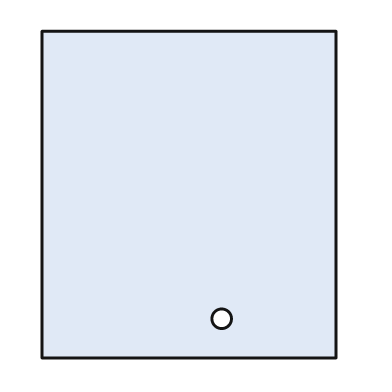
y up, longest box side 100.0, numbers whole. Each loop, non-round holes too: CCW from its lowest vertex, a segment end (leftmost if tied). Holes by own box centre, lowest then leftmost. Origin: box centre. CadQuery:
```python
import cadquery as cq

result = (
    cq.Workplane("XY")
    .moveTo(-45.0, -50.0)
    .lineTo(45.0, -50.0)
    .lineTo(45.0, 50.0)
    .lineTo(-45.0, 50.0)
    .close()
    .moveTo(10.0, -38.0)
    .circle(3.0)
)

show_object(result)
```